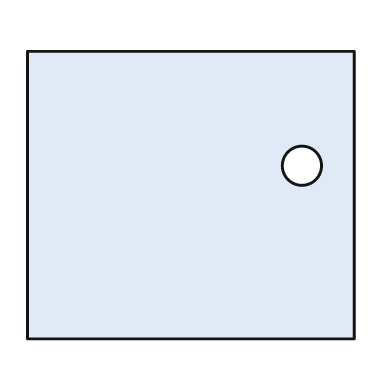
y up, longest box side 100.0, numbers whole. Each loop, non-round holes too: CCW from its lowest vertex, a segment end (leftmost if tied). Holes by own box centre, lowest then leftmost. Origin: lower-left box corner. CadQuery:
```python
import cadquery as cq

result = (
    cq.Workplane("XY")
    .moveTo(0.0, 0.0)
    .lineTo(100.0, 0.0)
    .lineTo(100.0, 88.0)
    .lineTo(0.0, 88.0)
    .close()
    .moveTo(84.0, 53.0)
    .circle(6.0)
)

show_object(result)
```